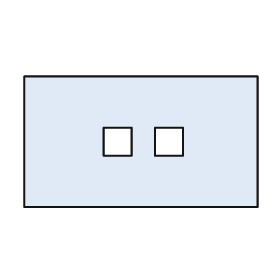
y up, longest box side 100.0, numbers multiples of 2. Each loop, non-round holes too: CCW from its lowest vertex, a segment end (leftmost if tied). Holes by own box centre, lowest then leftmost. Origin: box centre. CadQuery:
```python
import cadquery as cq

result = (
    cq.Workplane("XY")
    .moveTo(-50.0, -28.0)
    .lineTo(50.0, -28.0)
    .lineTo(50.0, 28.0)
    .lineTo(-50.0, 28.0)
    .close()
    .moveTo(-16.0, -6.0)
    .lineTo(-4.0, -6.0)
    .lineTo(-4.0, 6.0)
    .lineTo(-16.0, 6.0)
    .close()
    .moveTo(6.0, -6.0)
    .lineTo(18.0, -6.0)
    .lineTo(18.0, 6.0)
    .lineTo(6.0, 6.0)
    .close()
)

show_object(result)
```